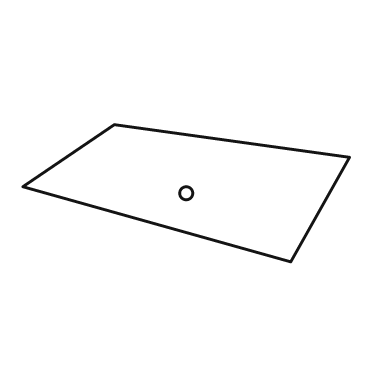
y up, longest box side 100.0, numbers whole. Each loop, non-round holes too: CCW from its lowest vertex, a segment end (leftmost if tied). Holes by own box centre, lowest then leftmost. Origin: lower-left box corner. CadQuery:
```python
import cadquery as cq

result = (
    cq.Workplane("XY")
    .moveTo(82.0, 0.0)
    .lineTo(100.0, 32.0)
    .lineTo(28.0, 42.0)
    .lineTo(0.0, 23.0)
    .close()
    .moveTo(50.0, 21.0)
    .circle(2.0)
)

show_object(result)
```